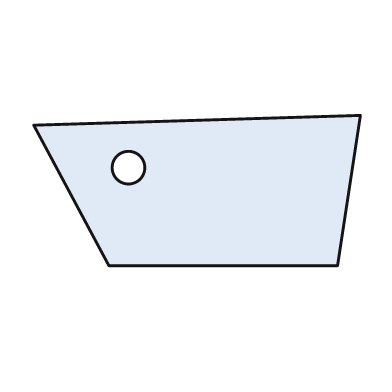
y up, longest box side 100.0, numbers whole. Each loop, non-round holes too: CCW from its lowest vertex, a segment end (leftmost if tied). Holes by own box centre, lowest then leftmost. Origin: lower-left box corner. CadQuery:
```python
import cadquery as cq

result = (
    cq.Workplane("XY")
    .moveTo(23.0, 0.0)
    .lineTo(93.0, 0.0)
    .lineTo(100.0, 46.0)
    .lineTo(0.0, 43.0)
    .close()
    .moveTo(29.0, 30.0)
    .circle(5.0)
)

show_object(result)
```